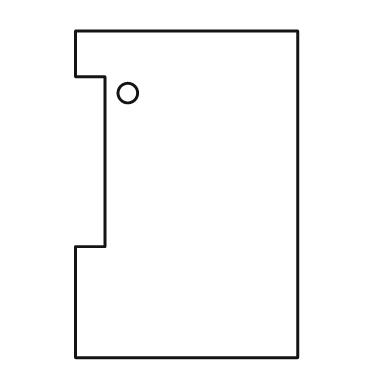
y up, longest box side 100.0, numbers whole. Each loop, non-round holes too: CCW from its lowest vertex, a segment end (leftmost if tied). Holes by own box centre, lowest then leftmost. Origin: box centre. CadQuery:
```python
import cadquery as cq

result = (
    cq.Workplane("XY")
    .moveTo(-34.0, -50.0)
    .lineTo(34.0, -50.0)
    .lineTo(34.0, 50.0)
    .lineTo(-34.0, 50.0)
    .lineTo(-34.0, 36.0)
    .lineTo(-25.0, 36.0)
    .lineTo(-25.0, -16.0)
    .lineTo(-34.0, -16.0)
    .close()
    .moveTo(-18.0, 31.0)
    .circle(3.0)
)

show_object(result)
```